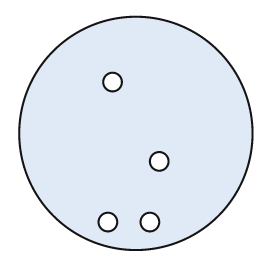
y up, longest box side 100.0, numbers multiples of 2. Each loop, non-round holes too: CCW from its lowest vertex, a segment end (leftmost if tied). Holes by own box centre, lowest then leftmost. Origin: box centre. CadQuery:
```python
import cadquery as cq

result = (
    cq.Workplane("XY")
    .moveTo(0.0, 0.0)
    .circle(50.0)
    .moveTo(-12.0, -38.0)
    .circle(4.0)
    .moveTo(6.0, -38.0)
    .circle(4.0)
    .moveTo(10.0, -12.0)
    .circle(4.0)
    .moveTo(-10.0, 22.0)
    .circle(4.0)
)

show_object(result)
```